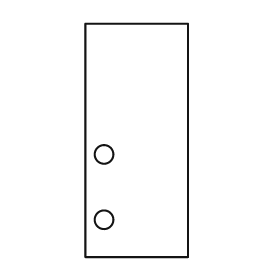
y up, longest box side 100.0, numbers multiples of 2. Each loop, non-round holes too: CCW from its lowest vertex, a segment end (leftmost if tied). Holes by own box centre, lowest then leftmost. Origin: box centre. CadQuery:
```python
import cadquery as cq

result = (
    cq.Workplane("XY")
    .moveTo(-22.0, -50.0)
    .lineTo(22.0, -50.0)
    .lineTo(22.0, 50.0)
    .lineTo(-22.0, 50.0)
    .close()
    .moveTo(-14.0, -34.0)
    .circle(4.0)
    .moveTo(-14.0, -6.0)
    .circle(4.0)
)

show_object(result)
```